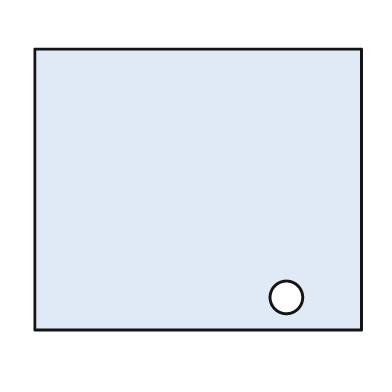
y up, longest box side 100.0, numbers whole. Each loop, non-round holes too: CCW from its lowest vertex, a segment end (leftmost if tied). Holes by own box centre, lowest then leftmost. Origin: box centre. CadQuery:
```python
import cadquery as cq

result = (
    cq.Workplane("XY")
    .moveTo(-50.0, -43.0)
    .lineTo(50.0, -43.0)
    .lineTo(50.0, 43.0)
    .lineTo(-50.0, 43.0)
    .close()
    .moveTo(27.0, -33.0)
    .circle(5.0)
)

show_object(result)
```